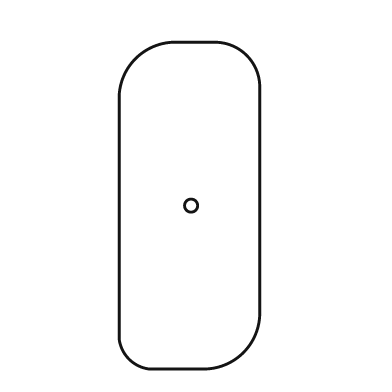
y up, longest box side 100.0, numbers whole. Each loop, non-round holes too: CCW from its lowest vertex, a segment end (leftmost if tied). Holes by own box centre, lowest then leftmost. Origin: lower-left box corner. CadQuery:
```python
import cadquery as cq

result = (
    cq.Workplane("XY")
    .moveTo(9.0, 0.0)
    .lineTo(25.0, 0.0)
    .threePointArc((38.0, 5.0), (43.0, 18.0))
    .lineTo(43.0, 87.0)
    .threePointArc((39.0, 96.0), (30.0, 100.0))
    .lineTo(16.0, 100.0)
    .threePointArc((5.0, 95.0), (0.0, 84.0))
    .lineTo(0.0, 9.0)
    .threePointArc((3.0, 3.0), (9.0, 0.0))
    .close()
    .moveTo(22.0, 50.0)
    .circle(2.0)
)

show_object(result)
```